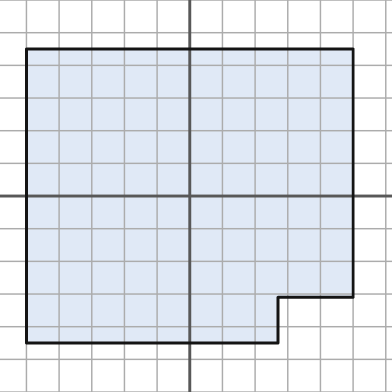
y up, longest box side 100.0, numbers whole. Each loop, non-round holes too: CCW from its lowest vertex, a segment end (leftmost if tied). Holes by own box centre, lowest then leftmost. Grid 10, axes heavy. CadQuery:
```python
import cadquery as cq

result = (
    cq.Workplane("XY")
    .moveTo(-50.0, -45.0)
    .lineTo(27.0, -45.0)
    .lineTo(27.0, -31.0)
    .lineTo(50.0, -31.0)
    .lineTo(50.0, 45.0)
    .lineTo(-50.0, 45.0)
    .close()
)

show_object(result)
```